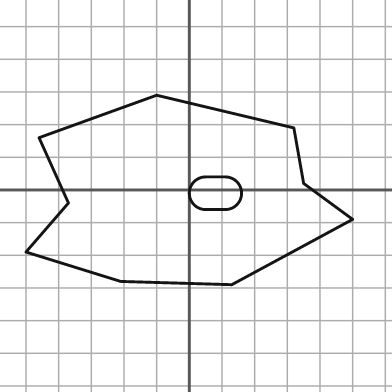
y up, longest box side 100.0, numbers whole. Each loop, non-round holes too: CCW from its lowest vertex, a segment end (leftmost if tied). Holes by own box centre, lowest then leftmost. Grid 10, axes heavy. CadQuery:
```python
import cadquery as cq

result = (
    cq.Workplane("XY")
    .moveTo(13.0, -29.0)
    .lineTo(50.0, -9.0)
    .lineTo(35.0, 2.0)
    .lineTo(32.0, 19.0)
    .lineTo(-10.0, 29.0)
    .lineTo(-46.0, 16.0)
    .lineTo(-37.0, -4.0)
    .lineTo(-50.0, -19.0)
    .lineTo(-21.0, -28.0)
    .close()
    .moveTo(5.0, -6.0)
    .lineTo(11.0, -6.0)
    .threePointArc((16.0, -1.0), (11.0, 4.0))
    .lineTo(5.0, 4.0)
    .threePointArc((0.0, -1.0), (5.0, -6.0))
    .close()
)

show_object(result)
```